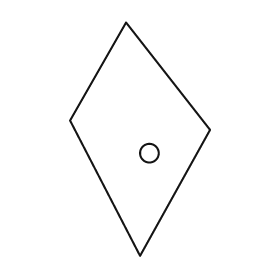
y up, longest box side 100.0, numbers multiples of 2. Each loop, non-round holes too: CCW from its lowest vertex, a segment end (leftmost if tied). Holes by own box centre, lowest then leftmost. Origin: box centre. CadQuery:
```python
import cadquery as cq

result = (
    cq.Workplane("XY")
    .moveTo(0.0, -50.0)
    .lineTo(30.0, 4.0)
    .lineTo(-6.0, 50.0)
    .lineTo(-30.0, 8.0)
    .close()
    .moveTo(4.0, -6.0)
    .circle(4.0)
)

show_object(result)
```